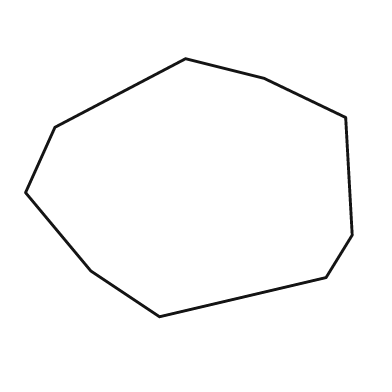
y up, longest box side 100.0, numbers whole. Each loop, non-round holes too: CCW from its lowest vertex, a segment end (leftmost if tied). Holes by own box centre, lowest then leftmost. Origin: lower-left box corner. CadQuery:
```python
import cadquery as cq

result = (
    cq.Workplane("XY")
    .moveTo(41.0, 0.0)
    .lineTo(92.0, 12.0)
    .lineTo(100.0, 25.0)
    .lineTo(98.0, 61.0)
    .lineTo(73.0, 73.0)
    .lineTo(49.0, 79.0)
    .lineTo(9.0, 58.0)
    .lineTo(0.0, 38.0)
    .lineTo(20.0, 14.0)
    .close()
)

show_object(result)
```